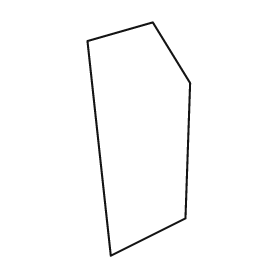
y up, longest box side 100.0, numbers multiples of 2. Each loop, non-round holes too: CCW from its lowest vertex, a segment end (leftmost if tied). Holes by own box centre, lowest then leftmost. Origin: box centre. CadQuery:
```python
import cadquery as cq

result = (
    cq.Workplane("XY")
    .moveTo(-12.0, -50.0)
    .lineTo(20.0, -34.0)
    .lineTo(22.0, 24.0)
    .lineTo(6.0, 50.0)
    .lineTo(-22.0, 42.0)
    .close()
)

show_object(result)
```